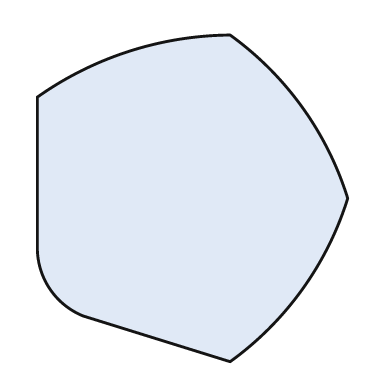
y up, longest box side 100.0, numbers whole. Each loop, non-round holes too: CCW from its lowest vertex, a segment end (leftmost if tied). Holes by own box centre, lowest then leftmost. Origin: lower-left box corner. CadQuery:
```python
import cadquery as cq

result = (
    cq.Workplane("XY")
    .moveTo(59.0, 0.0)
    .threePointArc((81.0, 22.0), (95.0, 50.0))
    .threePointArc((81.0, 78.0), (59.0, 100.0))
    .threePointArc((28.0, 95.0), (0.0, 81.0))
    .lineTo(0.0, 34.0)
    .threePointArc((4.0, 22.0), (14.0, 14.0))
    .close()
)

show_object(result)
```